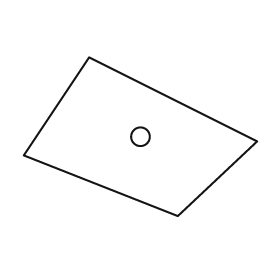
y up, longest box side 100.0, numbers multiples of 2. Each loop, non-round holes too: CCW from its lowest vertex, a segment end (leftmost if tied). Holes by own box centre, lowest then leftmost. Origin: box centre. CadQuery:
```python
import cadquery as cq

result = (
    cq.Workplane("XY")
    .moveTo(16.0, -34.0)
    .lineTo(50.0, -2.0)
    .lineTo(-22.0, 34.0)
    .lineTo(-50.0, -8.0)
    .close()
    .moveTo(0.0, 0.0)
    .circle(4.0)
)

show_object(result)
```